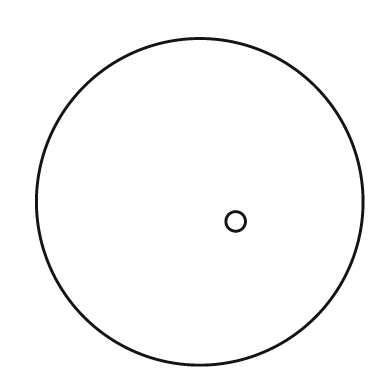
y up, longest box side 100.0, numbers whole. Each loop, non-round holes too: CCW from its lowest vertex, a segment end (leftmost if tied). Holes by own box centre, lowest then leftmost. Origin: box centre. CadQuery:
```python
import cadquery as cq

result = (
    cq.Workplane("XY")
    .moveTo(0.0, 0.0)
    .circle(50.0)
    .moveTo(11.0, -6.0)
    .circle(3.0)
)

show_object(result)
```